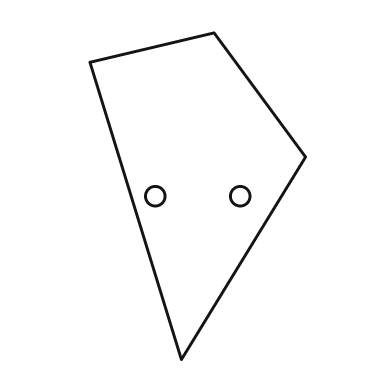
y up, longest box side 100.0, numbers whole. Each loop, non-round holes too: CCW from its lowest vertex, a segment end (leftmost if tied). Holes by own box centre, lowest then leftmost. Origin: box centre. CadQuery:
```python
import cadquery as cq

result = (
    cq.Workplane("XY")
    .moveTo(-5.0, -50.0)
    .lineTo(33.0, 12.0)
    .lineTo(5.0, 50.0)
    .lineTo(-33.0, 41.0)
    .close()
    .moveTo(-13.0, 0.0)
    .circle(3.0)
    .moveTo(13.0, 0.0)
    .circle(3.0)
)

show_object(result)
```